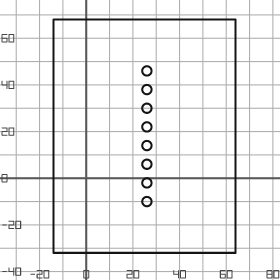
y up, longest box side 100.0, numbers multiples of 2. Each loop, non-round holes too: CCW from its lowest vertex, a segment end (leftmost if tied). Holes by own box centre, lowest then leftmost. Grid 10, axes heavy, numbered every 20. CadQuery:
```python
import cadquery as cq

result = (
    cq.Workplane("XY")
    .moveTo(-14.0, -32.0)
    .lineTo(64.0, -32.0)
    .lineTo(64.0, 68.0)
    .lineTo(-14.0, 68.0)
    .close()
    .moveTo(26.0, -10.0)
    .circle(2.0)
    .moveTo(26.0, -2.0)
    .circle(2.0)
    .moveTo(26.0, 6.0)
    .circle(2.0)
    .moveTo(26.0, 14.0)
    .circle(2.0)
    .moveTo(26.0, 22.0)
    .circle(2.0)
    .moveTo(26.0, 30.0)
    .circle(2.0)
    .moveTo(26.0, 38.0)
    .circle(2.0)
    .moveTo(26.0, 46.0)
    .circle(2.0)
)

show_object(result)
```